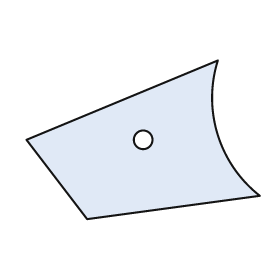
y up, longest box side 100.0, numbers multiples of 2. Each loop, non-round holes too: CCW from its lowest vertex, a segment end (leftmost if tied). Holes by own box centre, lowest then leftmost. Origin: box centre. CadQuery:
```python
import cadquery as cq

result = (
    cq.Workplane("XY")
    .moveTo(-24.0, -34.0)
    .lineTo(50.0, -24.0)
    .threePointArc((32.0, 2.0), (32.0, 34.0))
    .lineTo(-50.0, 0.0)
    .close()
    .moveTo(0.0, 0.0)
    .circle(4.0)
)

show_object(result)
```